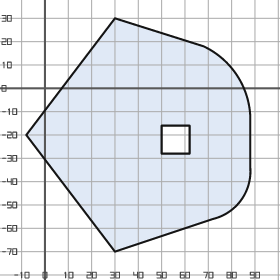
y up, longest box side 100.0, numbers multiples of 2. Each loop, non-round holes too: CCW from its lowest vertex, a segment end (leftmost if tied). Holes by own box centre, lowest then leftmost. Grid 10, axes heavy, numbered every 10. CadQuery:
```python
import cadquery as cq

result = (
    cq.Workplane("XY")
    .moveTo(30.0, -70.0)
    .lineTo(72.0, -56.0)
    .threePointArc((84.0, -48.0), (88.0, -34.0))
    .lineTo(88.0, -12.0)
    .threePointArc((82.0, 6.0), (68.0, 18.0))
    .lineTo(30.0, 30.0)
    .lineTo(-8.0, -20.0)
    .close()
    .moveTo(50.0, -28.0)
    .lineTo(62.0, -28.0)
    .lineTo(62.0, -16.0)
    .lineTo(50.0, -16.0)
    .close()
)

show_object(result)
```